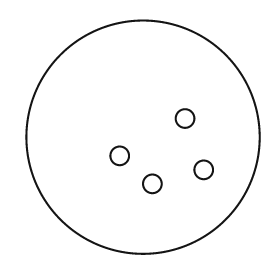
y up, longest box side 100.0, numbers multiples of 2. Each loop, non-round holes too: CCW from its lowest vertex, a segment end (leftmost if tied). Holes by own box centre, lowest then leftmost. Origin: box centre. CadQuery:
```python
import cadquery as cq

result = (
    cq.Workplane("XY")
    .moveTo(0.0, 0.0)
    .circle(50.0)
    .moveTo(4.0, -20.0)
    .circle(4.0)
    .moveTo(26.0, -14.0)
    .circle(4.0)
    .moveTo(-10.0, -8.0)
    .circle(4.0)
    .moveTo(18.0, 8.0)
    .circle(4.0)
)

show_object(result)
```